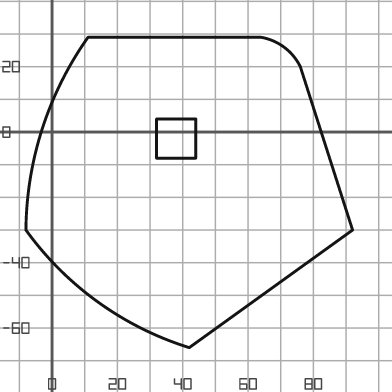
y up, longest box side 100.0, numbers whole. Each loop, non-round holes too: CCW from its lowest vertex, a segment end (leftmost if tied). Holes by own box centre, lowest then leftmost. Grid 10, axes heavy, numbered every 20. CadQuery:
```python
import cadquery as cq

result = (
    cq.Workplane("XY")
    .moveTo(42.0, -66.0)
    .lineTo(92.0, -30.0)
    .lineTo(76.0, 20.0)
    .threePointArc((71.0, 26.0), (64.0, 29.0))
    .lineTo(11.0, 29.0)
    .threePointArc((-3.0, 1.0), (-8.0, -30.0))
    .threePointArc((14.0, -52.0), (42.0, -66.0))
    .close()
    .moveTo(32.0, -8.0)
    .lineTo(44.0, -8.0)
    .lineTo(44.0, 4.0)
    .lineTo(32.0, 4.0)
    .close()
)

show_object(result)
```